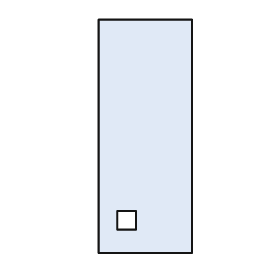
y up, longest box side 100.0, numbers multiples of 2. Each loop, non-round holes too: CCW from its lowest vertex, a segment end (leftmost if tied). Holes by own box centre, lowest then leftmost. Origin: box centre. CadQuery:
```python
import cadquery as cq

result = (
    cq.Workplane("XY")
    .moveTo(-20.0, -50.0)
    .lineTo(20.0, -50.0)
    .lineTo(20.0, 50.0)
    .lineTo(-20.0, 50.0)
    .close()
    .moveTo(-12.0, -40.0)
    .lineTo(-4.0, -40.0)
    .lineTo(-4.0, -32.0)
    .lineTo(-12.0, -32.0)
    .close()
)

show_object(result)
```